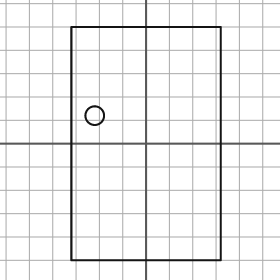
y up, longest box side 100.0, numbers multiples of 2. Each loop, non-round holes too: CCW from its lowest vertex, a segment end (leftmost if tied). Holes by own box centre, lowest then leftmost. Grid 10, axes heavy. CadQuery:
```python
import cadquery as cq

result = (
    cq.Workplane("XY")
    .moveTo(-32.0, -50.0)
    .lineTo(32.0, -50.0)
    .lineTo(32.0, 50.0)
    .lineTo(-32.0, 50.0)
    .close()
    .moveTo(-22.0, 12.0)
    .circle(4.0)
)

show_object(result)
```